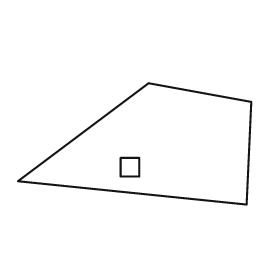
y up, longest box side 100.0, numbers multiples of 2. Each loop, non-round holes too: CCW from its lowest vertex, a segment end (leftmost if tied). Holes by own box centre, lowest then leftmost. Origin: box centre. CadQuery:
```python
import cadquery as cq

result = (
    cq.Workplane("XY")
    .moveTo(48.0, -26.0)
    .lineTo(50.0, 18.0)
    .lineTo(6.0, 26.0)
    .lineTo(-50.0, -16.0)
    .close()
    .moveTo(-6.0, -14.0)
    .lineTo(2.0, -14.0)
    .lineTo(2.0, -6.0)
    .lineTo(-6.0, -6.0)
    .close()
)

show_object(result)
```